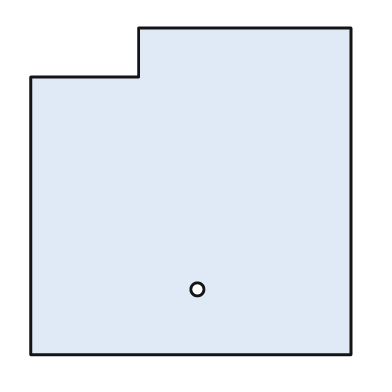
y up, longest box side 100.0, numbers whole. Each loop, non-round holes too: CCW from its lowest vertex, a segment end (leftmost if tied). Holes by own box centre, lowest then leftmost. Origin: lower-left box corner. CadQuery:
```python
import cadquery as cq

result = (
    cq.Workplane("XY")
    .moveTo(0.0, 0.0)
    .lineTo(98.0, 0.0)
    .lineTo(98.0, 100.0)
    .lineTo(33.0, 100.0)
    .lineTo(33.0, 85.0)
    .lineTo(0.0, 85.0)
    .close()
    .moveTo(51.0, 20.0)
    .circle(2.0)
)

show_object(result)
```